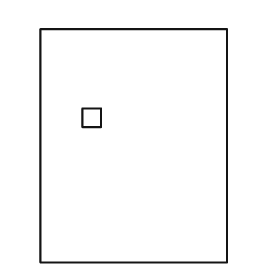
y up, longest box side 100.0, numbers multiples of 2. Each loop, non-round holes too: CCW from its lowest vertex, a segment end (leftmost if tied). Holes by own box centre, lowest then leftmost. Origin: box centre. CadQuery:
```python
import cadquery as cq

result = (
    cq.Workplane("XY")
    .moveTo(-40.0, -50.0)
    .lineTo(40.0, -50.0)
    .lineTo(40.0, 50.0)
    .lineTo(-40.0, 50.0)
    .close()
    .moveTo(-22.0, 8.0)
    .lineTo(-14.0, 8.0)
    .lineTo(-14.0, 16.0)
    .lineTo(-22.0, 16.0)
    .close()
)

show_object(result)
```